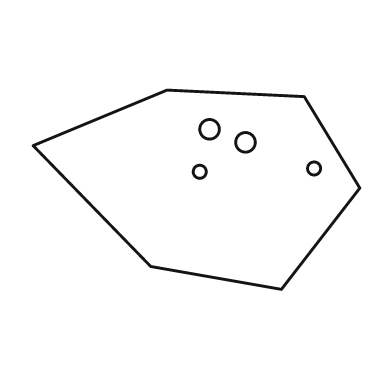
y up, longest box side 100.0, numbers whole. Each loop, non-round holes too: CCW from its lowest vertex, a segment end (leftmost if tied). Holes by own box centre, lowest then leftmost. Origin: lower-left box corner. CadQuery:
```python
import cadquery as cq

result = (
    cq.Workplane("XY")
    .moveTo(76.0, 0.0)
    .lineTo(100.0, 31.0)
    .lineTo(83.0, 59.0)
    .lineTo(41.0, 61.0)
    .lineTo(0.0, 44.0)
    .lineTo(36.0, 7.0)
    .close()
    .moveTo(51.0, 36.0)
    .circle(2.0)
    .moveTo(86.0, 37.0)
    .circle(2.0)
    .moveTo(65.0, 45.0)
    .circle(3.0)
    .moveTo(54.0, 49.0)
    .circle(3.0)
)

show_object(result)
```